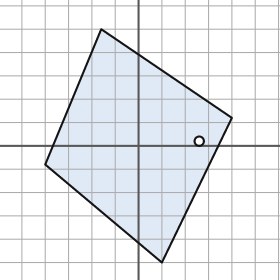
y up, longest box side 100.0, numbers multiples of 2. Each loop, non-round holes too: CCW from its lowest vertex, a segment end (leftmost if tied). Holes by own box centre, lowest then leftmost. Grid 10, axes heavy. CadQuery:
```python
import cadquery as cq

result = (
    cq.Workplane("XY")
    .moveTo(10.0, -50.0)
    .lineTo(40.0, 12.0)
    .lineTo(-16.0, 50.0)
    .lineTo(-40.0, -8.0)
    .close()
    .moveTo(26.0, 2.0)
    .circle(2.0)
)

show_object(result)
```